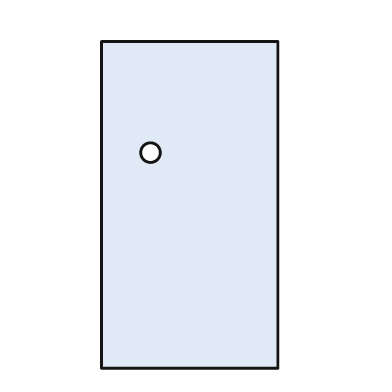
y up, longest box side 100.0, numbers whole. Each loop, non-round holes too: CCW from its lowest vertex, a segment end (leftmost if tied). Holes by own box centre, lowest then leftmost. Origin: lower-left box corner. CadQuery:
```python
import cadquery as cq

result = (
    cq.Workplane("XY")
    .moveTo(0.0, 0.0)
    .lineTo(54.0, 0.0)
    .lineTo(54.0, 100.0)
    .lineTo(0.0, 100.0)
    .close()
    .moveTo(15.0, 66.0)
    .circle(3.0)
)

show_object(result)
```